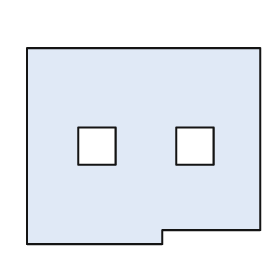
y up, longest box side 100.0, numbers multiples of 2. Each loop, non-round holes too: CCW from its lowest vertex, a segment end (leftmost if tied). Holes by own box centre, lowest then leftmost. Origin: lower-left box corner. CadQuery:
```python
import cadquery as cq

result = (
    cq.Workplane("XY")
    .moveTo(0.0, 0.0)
    .lineTo(58.0, 0.0)
    .lineTo(58.0, 6.0)
    .lineTo(100.0, 6.0)
    .lineTo(100.0, 84.0)
    .lineTo(0.0, 84.0)
    .close()
    .moveTo(22.0, 34.0)
    .lineTo(38.0, 34.0)
    .lineTo(38.0, 50.0)
    .lineTo(22.0, 50.0)
    .close()
    .moveTo(64.0, 34.0)
    .lineTo(80.0, 34.0)
    .lineTo(80.0, 50.0)
    .lineTo(64.0, 50.0)
    .close()
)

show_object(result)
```